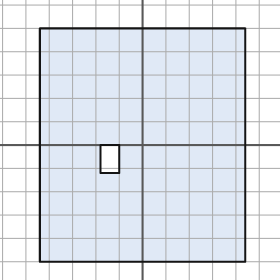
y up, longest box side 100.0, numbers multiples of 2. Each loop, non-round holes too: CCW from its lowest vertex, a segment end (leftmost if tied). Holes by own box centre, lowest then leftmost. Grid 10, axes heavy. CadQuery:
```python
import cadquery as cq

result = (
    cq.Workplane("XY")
    .moveTo(-44.0, -50.0)
    .lineTo(44.0, -50.0)
    .lineTo(44.0, 50.0)
    .lineTo(-44.0, 50.0)
    .close()
    .moveTo(-18.0, -12.0)
    .lineTo(-10.0, -12.0)
    .lineTo(-10.0, 0.0)
    .lineTo(-18.0, 0.0)
    .close()
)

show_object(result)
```